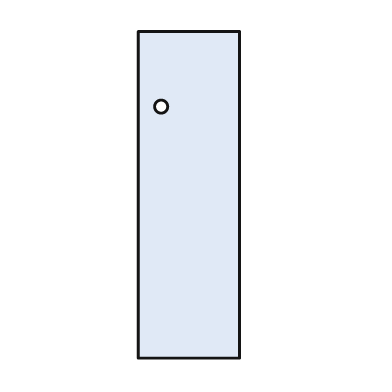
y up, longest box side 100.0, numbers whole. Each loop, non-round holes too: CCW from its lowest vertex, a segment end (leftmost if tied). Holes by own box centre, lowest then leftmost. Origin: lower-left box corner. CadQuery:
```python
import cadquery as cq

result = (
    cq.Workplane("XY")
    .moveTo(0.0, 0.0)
    .lineTo(31.0, 0.0)
    .lineTo(31.0, 100.0)
    .lineTo(0.0, 100.0)
    .close()
    .moveTo(7.0, 77.0)
    .circle(2.0)
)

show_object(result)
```